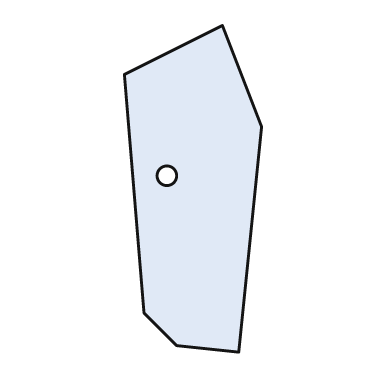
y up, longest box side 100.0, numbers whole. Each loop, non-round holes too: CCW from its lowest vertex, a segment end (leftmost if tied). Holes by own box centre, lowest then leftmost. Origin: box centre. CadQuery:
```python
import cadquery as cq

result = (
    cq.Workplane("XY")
    .moveTo(14.0, -50.0)
    .lineTo(21.0, 19.0)
    .lineTo(9.0, 50.0)
    .lineTo(-21.0, 35.0)
    .lineTo(-15.0, -38.0)
    .lineTo(-5.0, -48.0)
    .close()
    .moveTo(-8.0, 4.0)
    .circle(3.0)
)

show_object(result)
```